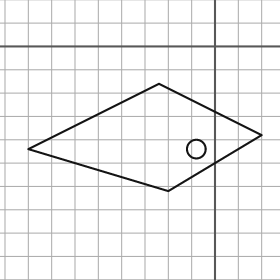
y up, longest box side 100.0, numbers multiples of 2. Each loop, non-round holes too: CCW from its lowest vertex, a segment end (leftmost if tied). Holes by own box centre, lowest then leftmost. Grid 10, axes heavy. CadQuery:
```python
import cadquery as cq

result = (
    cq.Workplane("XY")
    .moveTo(-20.0, -62.0)
    .lineTo(20.0, -38.0)
    .lineTo(-24.0, -16.0)
    .lineTo(-80.0, -44.0)
    .close()
    .moveTo(-8.0, -44.0)
    .circle(4.0)
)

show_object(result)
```